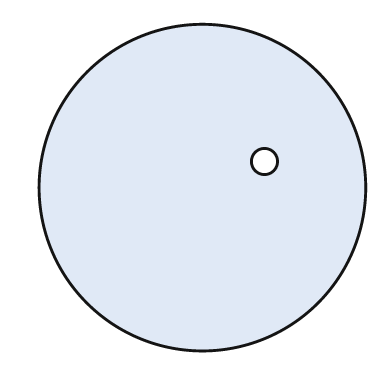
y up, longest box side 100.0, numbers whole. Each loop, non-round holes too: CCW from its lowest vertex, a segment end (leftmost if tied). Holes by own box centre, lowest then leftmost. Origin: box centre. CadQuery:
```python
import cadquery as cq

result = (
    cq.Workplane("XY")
    .moveTo(0.0, 0.0)
    .circle(50.0)
    .moveTo(19.0, 8.0)
    .circle(4.0)
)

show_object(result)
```